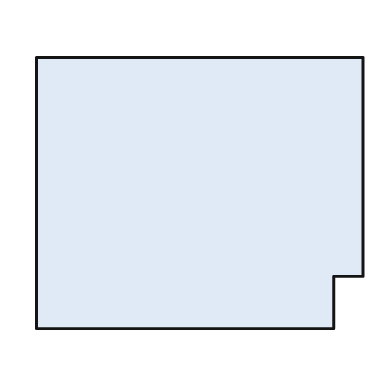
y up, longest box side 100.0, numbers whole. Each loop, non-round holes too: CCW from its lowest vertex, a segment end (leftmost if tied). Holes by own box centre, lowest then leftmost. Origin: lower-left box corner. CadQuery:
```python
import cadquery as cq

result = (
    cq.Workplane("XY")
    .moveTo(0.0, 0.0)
    .lineTo(91.0, 0.0)
    .lineTo(91.0, 16.0)
    .lineTo(100.0, 16.0)
    .lineTo(100.0, 83.0)
    .lineTo(0.0, 83.0)
    .close()
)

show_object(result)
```